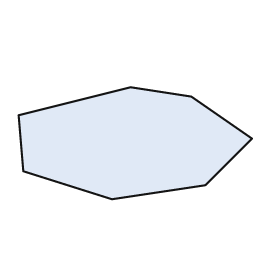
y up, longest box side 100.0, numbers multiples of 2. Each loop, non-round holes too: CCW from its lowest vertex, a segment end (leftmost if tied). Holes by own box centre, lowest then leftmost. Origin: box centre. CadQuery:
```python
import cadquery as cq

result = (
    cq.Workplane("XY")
    .moveTo(-10.0, -24.0)
    .lineTo(30.0, -18.0)
    .lineTo(50.0, 2.0)
    .lineTo(24.0, 20.0)
    .lineTo(-2.0, 24.0)
    .lineTo(-50.0, 12.0)
    .lineTo(-48.0, -12.0)
    .close()
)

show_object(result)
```